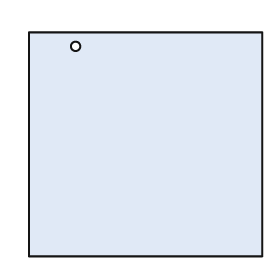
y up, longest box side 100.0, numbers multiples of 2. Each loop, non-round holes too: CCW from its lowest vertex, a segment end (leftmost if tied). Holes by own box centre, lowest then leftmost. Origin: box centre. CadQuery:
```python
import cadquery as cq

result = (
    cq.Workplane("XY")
    .moveTo(-50.0, -48.0)
    .lineTo(50.0, -48.0)
    .lineTo(50.0, 48.0)
    .lineTo(-50.0, 48.0)
    .close()
    .moveTo(-30.0, 42.0)
    .circle(2.0)
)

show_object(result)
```